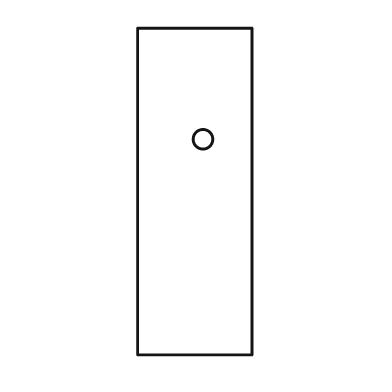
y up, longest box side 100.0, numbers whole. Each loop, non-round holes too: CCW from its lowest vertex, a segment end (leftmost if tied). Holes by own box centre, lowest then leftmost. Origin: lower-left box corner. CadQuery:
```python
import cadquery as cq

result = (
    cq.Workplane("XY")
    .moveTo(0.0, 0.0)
    .lineTo(35.0, 0.0)
    .lineTo(35.0, 100.0)
    .lineTo(0.0, 100.0)
    .close()
    .moveTo(20.0, 66.0)
    .circle(3.0)
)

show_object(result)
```